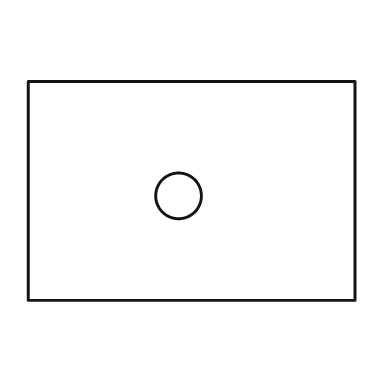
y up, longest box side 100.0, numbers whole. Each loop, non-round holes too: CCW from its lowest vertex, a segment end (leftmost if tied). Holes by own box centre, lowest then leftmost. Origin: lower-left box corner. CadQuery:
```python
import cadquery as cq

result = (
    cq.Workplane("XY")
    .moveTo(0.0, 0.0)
    .lineTo(100.0, 0.0)
    .lineTo(100.0, 67.0)
    .lineTo(0.0, 67.0)
    .close()
    .moveTo(46.0, 32.0)
    .circle(7.0)
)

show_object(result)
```